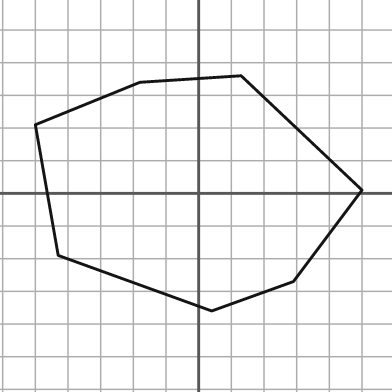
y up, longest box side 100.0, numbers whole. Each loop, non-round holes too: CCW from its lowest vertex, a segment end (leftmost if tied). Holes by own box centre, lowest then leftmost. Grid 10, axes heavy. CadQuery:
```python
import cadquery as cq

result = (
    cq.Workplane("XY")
    .moveTo(4.0, -36.0)
    .lineTo(29.0, -27.0)
    .lineTo(50.0, 1.0)
    .lineTo(13.0, 36.0)
    .lineTo(-18.0, 34.0)
    .lineTo(-50.0, 21.0)
    .lineTo(-43.0, -19.0)
    .close()
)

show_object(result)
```